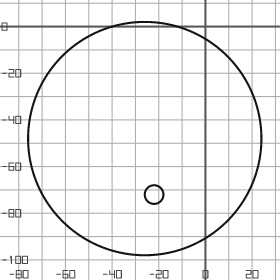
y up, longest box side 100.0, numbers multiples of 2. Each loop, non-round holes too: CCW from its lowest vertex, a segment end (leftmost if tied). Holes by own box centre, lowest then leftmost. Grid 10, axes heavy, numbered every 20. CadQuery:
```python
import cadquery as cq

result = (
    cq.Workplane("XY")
    .moveTo(-26.0, -48.0)
    .circle(50.0)
    .moveTo(-22.0, -72.0)
    .circle(4.0)
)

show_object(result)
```